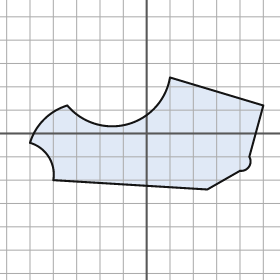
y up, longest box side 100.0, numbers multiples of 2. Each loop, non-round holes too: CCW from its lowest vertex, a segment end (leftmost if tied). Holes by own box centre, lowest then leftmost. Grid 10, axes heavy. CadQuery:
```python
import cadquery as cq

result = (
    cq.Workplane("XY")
    .moveTo(26.0, -24.0)
    .lineTo(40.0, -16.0)
    .threePointArc((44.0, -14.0), (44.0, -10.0))
    .lineTo(50.0, 12.0)
    .lineTo(10.0, 24.0)
    .threePointArc((-8.0, 4.0), (-34.0, 12.0))
    .threePointArc((-44.0, 6.0), (-50.0, -4.0))
    .threePointArc((-42.0, -10.0), (-40.0, -20.0))
    .close()
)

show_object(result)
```